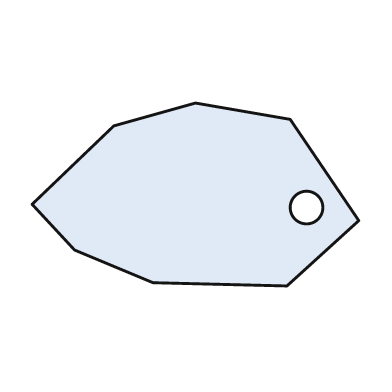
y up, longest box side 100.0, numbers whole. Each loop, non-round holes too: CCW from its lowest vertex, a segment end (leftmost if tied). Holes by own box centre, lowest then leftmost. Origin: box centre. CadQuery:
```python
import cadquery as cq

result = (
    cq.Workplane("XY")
    .moveTo(28.0, -28.0)
    .lineTo(50.0, -8.0)
    .lineTo(29.0, 23.0)
    .lineTo(0.0, 28.0)
    .lineTo(-25.0, 21.0)
    .lineTo(-50.0, -3.0)
    .lineTo(-37.0, -17.0)
    .lineTo(-13.0, -27.0)
    .close()
    .moveTo(34.0, -4.0)
    .circle(5.0)
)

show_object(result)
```